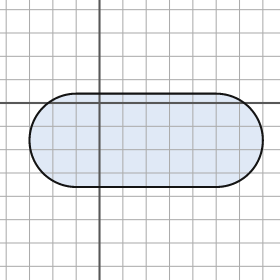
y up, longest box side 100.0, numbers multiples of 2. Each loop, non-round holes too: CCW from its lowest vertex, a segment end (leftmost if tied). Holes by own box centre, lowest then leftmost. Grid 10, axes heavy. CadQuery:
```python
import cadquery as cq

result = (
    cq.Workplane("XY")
    .moveTo(-10.0, -36.0)
    .lineTo(50.0, -36.0)
    .threePointArc((70.0, -16.0), (50.0, 4.0))
    .lineTo(-10.0, 4.0)
    .threePointArc((-30.0, -16.0), (-10.0, -36.0))
    .close()
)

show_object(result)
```